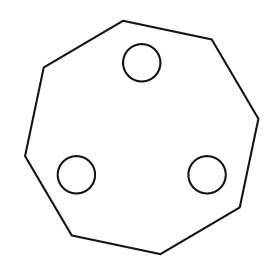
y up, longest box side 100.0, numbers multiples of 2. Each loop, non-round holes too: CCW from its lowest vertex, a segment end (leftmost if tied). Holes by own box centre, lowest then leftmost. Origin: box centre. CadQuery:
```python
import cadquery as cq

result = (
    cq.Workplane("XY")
    .moveTo(8.0, -50.0)
    .lineTo(42.0, -30.0)
    .lineTo(50.0, 8.0)
    .lineTo(30.0, 42.0)
    .lineTo(-8.0, 50.0)
    .lineTo(-42.0, 30.0)
    .lineTo(-50.0, -8.0)
    .lineTo(-30.0, -42.0)
    .close()
    .moveTo(-28.0, -16.0)
    .circle(8.0)
    .moveTo(28.0, -16.0)
    .circle(8.0)
    .moveTo(0.0, 32.0)
    .circle(8.0)
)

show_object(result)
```